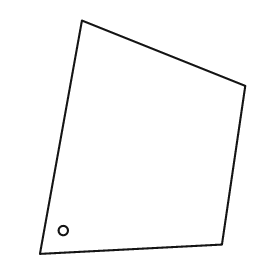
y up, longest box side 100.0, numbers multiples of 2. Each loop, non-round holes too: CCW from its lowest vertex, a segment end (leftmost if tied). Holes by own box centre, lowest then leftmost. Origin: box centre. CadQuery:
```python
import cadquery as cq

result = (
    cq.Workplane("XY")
    .moveTo(-44.0, -50.0)
    .lineTo(34.0, -46.0)
    .lineTo(44.0, 22.0)
    .lineTo(-26.0, 50.0)
    .close()
    .moveTo(-34.0, -40.0)
    .circle(2.0)
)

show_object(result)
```